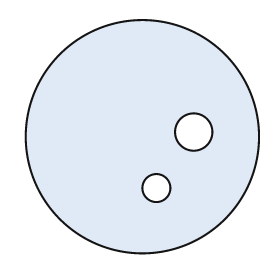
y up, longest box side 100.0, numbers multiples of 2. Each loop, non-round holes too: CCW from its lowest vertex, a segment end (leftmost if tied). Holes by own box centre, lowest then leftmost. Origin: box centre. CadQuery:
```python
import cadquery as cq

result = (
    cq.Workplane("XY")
    .moveTo(0.0, 0.0)
    .circle(50.0)
    .moveTo(6.0, -22.0)
    .circle(6.0)
    .moveTo(22.0, 2.0)
    .circle(8.0)
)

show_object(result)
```